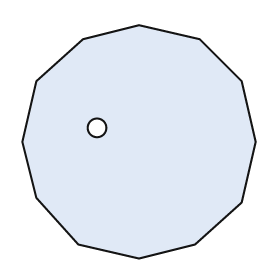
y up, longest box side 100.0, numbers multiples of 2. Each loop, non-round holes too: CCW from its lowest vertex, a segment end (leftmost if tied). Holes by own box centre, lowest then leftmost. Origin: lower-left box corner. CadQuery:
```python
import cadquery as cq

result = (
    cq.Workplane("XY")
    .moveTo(50.0, 0.0)
    .lineTo(74.0, 6.0)
    .lineTo(94.0, 24.0)
    .lineTo(100.0, 50.0)
    .lineTo(94.0, 76.0)
    .lineTo(76.0, 94.0)
    .lineTo(50.0, 100.0)
    .lineTo(26.0, 94.0)
    .lineTo(6.0, 76.0)
    .lineTo(0.0, 50.0)
    .lineTo(6.0, 26.0)
    .lineTo(24.0, 6.0)
    .close()
    .moveTo(32.0, 56.0)
    .circle(4.0)
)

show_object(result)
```